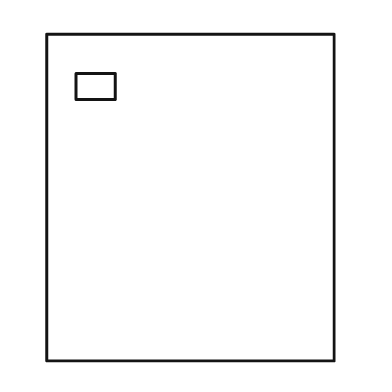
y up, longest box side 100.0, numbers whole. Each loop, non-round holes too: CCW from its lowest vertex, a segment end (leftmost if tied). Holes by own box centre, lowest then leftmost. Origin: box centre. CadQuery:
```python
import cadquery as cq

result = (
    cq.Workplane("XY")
    .moveTo(-44.0, -50.0)
    .lineTo(44.0, -50.0)
    .lineTo(44.0, 50.0)
    .lineTo(-44.0, 50.0)
    .close()
    .moveTo(-35.0, 30.0)
    .lineTo(-23.0, 30.0)
    .lineTo(-23.0, 38.0)
    .lineTo(-35.0, 38.0)
    .close()
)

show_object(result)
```